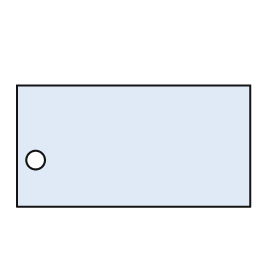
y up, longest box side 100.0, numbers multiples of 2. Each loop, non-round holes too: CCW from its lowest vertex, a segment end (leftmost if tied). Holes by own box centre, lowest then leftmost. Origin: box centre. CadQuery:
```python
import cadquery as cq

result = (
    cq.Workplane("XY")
    .moveTo(-50.0, -26.0)
    .lineTo(50.0, -26.0)
    .lineTo(50.0, 26.0)
    .lineTo(-50.0, 26.0)
    .close()
    .moveTo(-42.0, -6.0)
    .circle(4.0)
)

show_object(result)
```